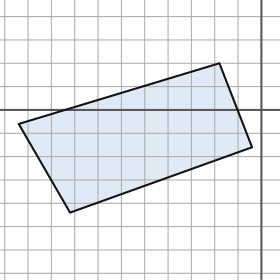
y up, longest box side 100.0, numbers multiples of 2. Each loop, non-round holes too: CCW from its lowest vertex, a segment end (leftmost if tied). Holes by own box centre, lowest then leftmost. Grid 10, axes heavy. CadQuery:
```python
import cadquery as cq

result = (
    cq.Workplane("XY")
    .moveTo(-82.0, -44.0)
    .lineTo(-4.0, -16.0)
    .lineTo(-18.0, 20.0)
    .lineTo(-104.0, -6.0)
    .close()
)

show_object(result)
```